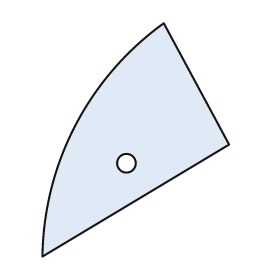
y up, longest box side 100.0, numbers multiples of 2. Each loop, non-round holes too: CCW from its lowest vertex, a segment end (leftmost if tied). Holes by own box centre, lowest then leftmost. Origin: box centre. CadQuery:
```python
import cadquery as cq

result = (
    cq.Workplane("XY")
    .moveTo(-40.0, -50.0)
    .lineTo(40.0, -2.0)
    .lineTo(12.0, 50.0)
    .threePointArc((-26.0, 6.0), (-40.0, -50.0))
    .close()
    .moveTo(-4.0, -10.0)
    .circle(4.0)
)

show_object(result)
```